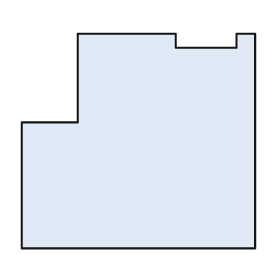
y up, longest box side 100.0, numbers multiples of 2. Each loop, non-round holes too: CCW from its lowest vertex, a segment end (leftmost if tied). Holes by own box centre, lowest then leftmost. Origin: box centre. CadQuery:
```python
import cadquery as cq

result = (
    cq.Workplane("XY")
    .moveTo(-50.0, -46.0)
    .lineTo(50.0, -46.0)
    .lineTo(50.0, 46.0)
    .lineTo(42.0, 46.0)
    .lineTo(42.0, 40.0)
    .lineTo(16.0, 40.0)
    .lineTo(16.0, 46.0)
    .lineTo(-26.0, 46.0)
    .lineTo(-26.0, 8.0)
    .lineTo(-50.0, 8.0)
    .close()
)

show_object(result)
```